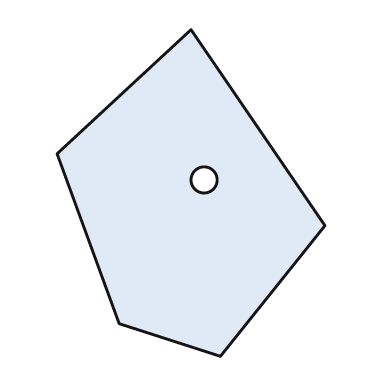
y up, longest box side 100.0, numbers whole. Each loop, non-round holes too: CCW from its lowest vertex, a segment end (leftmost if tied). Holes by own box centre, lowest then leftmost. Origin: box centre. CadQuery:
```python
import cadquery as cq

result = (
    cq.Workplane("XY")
    .moveTo(9.0, -50.0)
    .lineTo(41.0, -10.0)
    .lineTo(0.0, 50.0)
    .lineTo(-41.0, 12.0)
    .lineTo(-22.0, -40.0)
    .close()
    .moveTo(4.0, 4.0)
    .circle(4.0)
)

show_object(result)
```